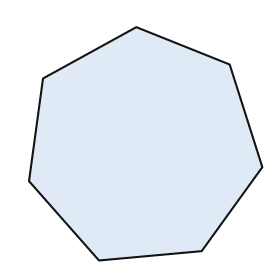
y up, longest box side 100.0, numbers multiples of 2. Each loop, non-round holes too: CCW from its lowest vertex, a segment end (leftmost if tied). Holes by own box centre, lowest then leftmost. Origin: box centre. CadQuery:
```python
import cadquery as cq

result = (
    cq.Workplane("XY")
    .moveTo(-20.0, -50.0)
    .lineTo(24.0, -46.0)
    .lineTo(50.0, -10.0)
    .lineTo(36.0, 34.0)
    .lineTo(-4.0, 50.0)
    .lineTo(-44.0, 28.0)
    .lineTo(-50.0, -16.0)
    .close()
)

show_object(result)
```